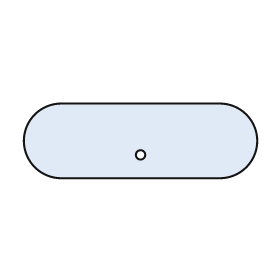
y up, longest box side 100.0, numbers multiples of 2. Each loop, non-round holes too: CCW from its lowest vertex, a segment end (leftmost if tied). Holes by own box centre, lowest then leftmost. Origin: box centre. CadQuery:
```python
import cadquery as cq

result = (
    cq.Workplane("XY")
    .moveTo(-34.0, -16.0)
    .lineTo(34.0, -16.0)
    .threePointArc((50.0, 0.0), (34.0, 16.0))
    .lineTo(-34.0, 16.0)
    .threePointArc((-50.0, 0.0), (-34.0, -16.0))
    .close()
    .moveTo(0.0, -6.0)
    .circle(2.0)
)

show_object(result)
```